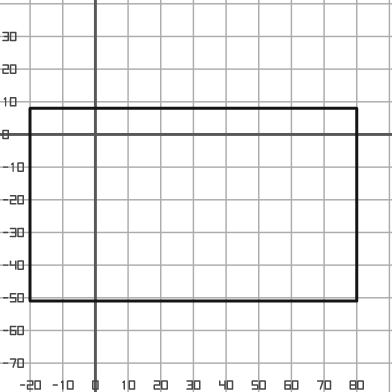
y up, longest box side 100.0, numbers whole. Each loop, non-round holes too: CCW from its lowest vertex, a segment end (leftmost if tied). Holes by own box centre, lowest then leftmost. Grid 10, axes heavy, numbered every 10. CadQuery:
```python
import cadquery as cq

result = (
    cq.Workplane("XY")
    .moveTo(-20.0, -51.0)
    .lineTo(80.0, -51.0)
    .lineTo(80.0, 8.0)
    .lineTo(-20.0, 8.0)
    .close()
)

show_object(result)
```